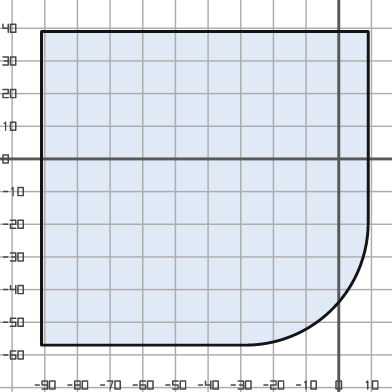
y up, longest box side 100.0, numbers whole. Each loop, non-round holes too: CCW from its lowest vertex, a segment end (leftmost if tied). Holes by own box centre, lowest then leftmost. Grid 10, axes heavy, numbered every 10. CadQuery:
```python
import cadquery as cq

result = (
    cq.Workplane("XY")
    .moveTo(-91.0, -57.0)
    .lineTo(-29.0, -57.0)
    .threePointArc((-2.0, -46.0), (9.0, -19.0))
    .lineTo(9.0, 39.0)
    .lineTo(-91.0, 39.0)
    .close()
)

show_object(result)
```